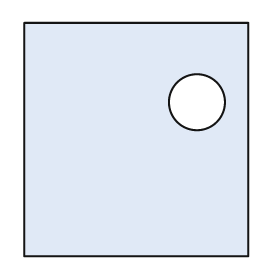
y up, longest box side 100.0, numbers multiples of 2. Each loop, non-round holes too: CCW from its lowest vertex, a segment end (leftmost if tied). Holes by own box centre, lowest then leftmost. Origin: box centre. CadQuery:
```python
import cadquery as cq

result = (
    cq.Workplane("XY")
    .moveTo(-48.0, -50.0)
    .lineTo(48.0, -50.0)
    .lineTo(48.0, 50.0)
    .lineTo(-48.0, 50.0)
    .close()
    .moveTo(26.0, 16.0)
    .circle(12.0)
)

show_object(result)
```